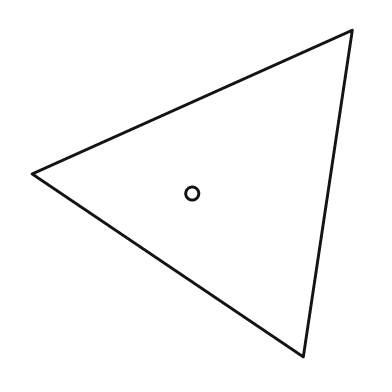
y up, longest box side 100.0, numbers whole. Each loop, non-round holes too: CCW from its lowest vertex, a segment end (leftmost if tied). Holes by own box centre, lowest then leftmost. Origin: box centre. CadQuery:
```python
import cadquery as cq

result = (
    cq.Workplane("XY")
    .moveTo(34.0, -50.0)
    .lineTo(49.0, 50.0)
    .lineTo(-49.0, 6.0)
    .close()
    .moveTo(0.0, 0.0)
    .circle(2.0)
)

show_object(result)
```